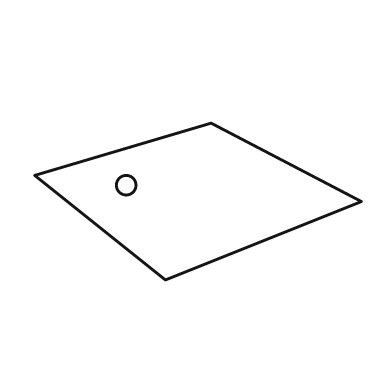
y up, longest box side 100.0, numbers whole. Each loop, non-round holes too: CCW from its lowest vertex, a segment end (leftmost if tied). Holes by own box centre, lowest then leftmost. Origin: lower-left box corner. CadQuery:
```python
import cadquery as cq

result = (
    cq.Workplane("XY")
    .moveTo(40.0, 0.0)
    .lineTo(100.0, 24.0)
    .lineTo(54.0, 48.0)
    .lineTo(0.0, 32.0)
    .close()
    .moveTo(28.0, 29.0)
    .circle(3.0)
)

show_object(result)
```